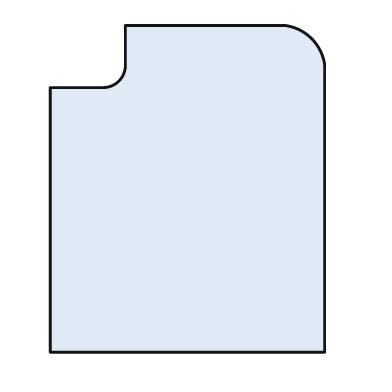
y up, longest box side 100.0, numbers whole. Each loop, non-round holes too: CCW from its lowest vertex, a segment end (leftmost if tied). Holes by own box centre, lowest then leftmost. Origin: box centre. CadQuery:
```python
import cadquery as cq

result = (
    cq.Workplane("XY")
    .moveTo(-42.0, -50.0)
    .lineTo(42.0, -50.0)
    .lineTo(42.0, 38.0)
    .threePointArc((38.0, 46.0), (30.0, 50.0))
    .lineTo(-19.0, 50.0)
    .lineTo(-19.0, 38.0)
    .threePointArc((-21.0, 33.0), (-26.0, 31.0))
    .lineTo(-42.0, 31.0)
    .close()
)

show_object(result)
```